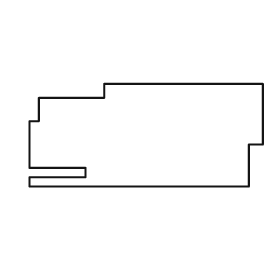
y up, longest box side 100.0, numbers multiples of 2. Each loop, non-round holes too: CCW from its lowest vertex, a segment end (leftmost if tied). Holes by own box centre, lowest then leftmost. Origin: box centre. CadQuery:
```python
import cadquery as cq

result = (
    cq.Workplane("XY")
    .moveTo(-50.0, -22.0)
    .lineTo(44.0, -22.0)
    .lineTo(44.0, -4.0)
    .lineTo(50.0, -4.0)
    .lineTo(50.0, 22.0)
    .lineTo(-18.0, 22.0)
    .lineTo(-18.0, 16.0)
    .lineTo(-46.0, 16.0)
    .lineTo(-46.0, 6.0)
    .lineTo(-50.0, 6.0)
    .lineTo(-50.0, -14.0)
    .lineTo(-26.0, -14.0)
    .lineTo(-26.0, -18.0)
    .lineTo(-50.0, -18.0)
    .close()
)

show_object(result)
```